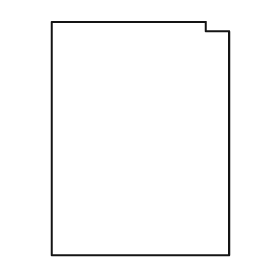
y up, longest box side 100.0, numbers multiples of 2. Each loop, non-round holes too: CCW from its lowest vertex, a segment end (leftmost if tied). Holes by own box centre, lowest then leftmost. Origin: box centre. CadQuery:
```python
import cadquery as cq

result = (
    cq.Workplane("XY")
    .moveTo(-38.0, -50.0)
    .lineTo(38.0, -50.0)
    .lineTo(38.0, 46.0)
    .lineTo(28.0, 46.0)
    .lineTo(28.0, 50.0)
    .lineTo(-38.0, 50.0)
    .close()
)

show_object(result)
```